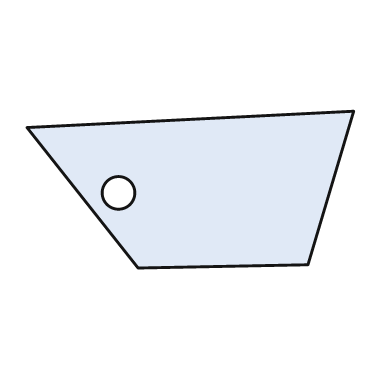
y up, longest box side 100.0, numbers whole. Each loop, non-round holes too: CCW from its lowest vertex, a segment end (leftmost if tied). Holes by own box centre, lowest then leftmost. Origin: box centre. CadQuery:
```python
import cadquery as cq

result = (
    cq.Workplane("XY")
    .moveTo(-16.0, -24.0)
    .lineTo(36.0, -23.0)
    .lineTo(50.0, 24.0)
    .lineTo(-50.0, 19.0)
    .close()
    .moveTo(-22.0, -1.0)
    .circle(5.0)
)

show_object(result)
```